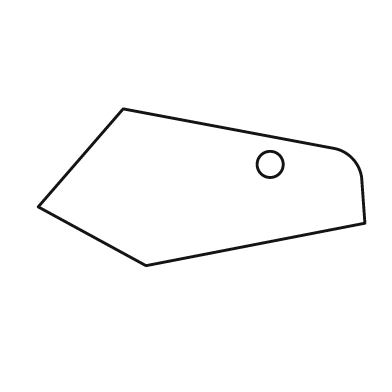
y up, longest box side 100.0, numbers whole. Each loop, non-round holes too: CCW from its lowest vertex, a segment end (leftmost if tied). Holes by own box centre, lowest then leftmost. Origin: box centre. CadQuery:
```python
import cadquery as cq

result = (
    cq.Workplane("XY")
    .moveTo(-17.0, -24.0)
    .lineTo(50.0, -11.0)
    .lineTo(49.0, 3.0)
    .threePointArc((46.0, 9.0), (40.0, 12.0))
    .lineTo(-24.0, 24.0)
    .lineTo(-50.0, -6.0)
    .close()
    .moveTo(21.0, 7.0)
    .circle(4.0)
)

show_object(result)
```